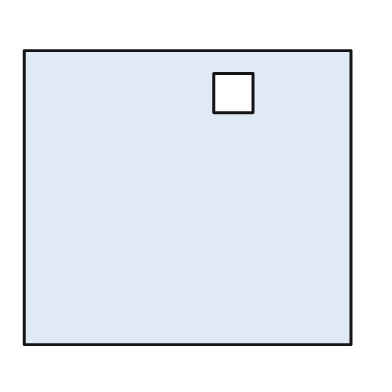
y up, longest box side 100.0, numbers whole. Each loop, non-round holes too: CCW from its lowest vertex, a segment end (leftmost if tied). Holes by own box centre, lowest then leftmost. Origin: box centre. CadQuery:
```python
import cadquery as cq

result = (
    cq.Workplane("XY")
    .moveTo(-50.0, -45.0)
    .lineTo(50.0, -45.0)
    .lineTo(50.0, 45.0)
    .lineTo(-50.0, 45.0)
    .close()
    .moveTo(8.0, 26.0)
    .lineTo(20.0, 26.0)
    .lineTo(20.0, 38.0)
    .lineTo(8.0, 38.0)
    .close()
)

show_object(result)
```